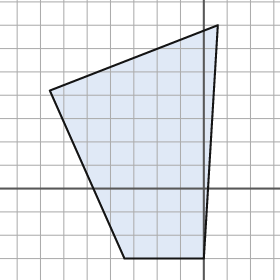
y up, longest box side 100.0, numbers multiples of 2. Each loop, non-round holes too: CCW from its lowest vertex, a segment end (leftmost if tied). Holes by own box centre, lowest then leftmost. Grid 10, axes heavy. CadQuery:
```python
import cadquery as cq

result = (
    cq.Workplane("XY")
    .moveTo(-34.0, -30.0)
    .lineTo(0.0, -30.0)
    .lineTo(6.0, 70.0)
    .lineTo(-66.0, 42.0)
    .close()
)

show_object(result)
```